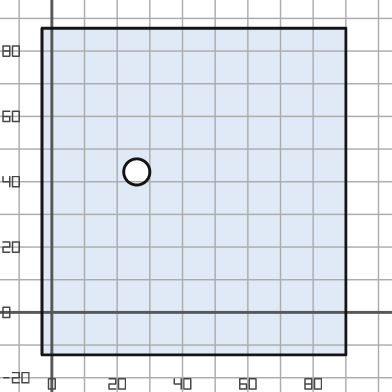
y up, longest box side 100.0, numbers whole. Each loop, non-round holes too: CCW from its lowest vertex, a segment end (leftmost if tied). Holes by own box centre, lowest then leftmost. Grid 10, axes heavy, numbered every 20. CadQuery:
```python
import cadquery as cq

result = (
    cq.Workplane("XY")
    .moveTo(-3.0, -13.0)
    .lineTo(90.0, -13.0)
    .lineTo(90.0, 87.0)
    .lineTo(-3.0, 87.0)
    .close()
    .moveTo(26.0, 43.0)
    .circle(4.0)
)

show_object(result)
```